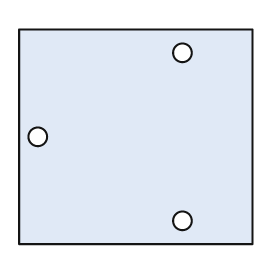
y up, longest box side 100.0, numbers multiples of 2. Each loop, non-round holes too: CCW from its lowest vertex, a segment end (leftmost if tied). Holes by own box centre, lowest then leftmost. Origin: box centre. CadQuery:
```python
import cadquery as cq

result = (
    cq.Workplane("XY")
    .moveTo(-50.0, -46.0)
    .lineTo(50.0, -46.0)
    .lineTo(50.0, 46.0)
    .lineTo(-50.0, 46.0)
    .close()
    .moveTo(20.0, -36.0)
    .circle(4.0)
    .moveTo(-42.0, 0.0)
    .circle(4.0)
    .moveTo(20.0, 36.0)
    .circle(4.0)
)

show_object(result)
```